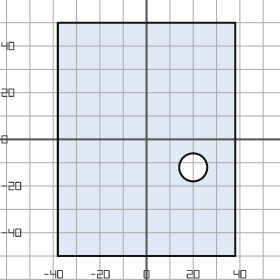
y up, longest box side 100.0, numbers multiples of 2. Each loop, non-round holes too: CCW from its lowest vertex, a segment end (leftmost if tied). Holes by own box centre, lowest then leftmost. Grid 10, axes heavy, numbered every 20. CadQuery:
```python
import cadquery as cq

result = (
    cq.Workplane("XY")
    .moveTo(-38.0, -50.0)
    .lineTo(38.0, -50.0)
    .lineTo(38.0, 50.0)
    .lineTo(-38.0, 50.0)
    .close()
    .moveTo(20.0, -12.0)
    .circle(6.0)
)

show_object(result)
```